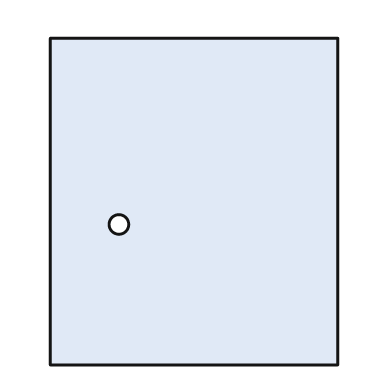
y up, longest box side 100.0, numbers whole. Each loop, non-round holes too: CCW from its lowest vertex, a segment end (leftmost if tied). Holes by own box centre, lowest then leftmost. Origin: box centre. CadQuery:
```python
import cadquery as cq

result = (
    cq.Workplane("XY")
    .moveTo(-44.0, -50.0)
    .lineTo(44.0, -50.0)
    .lineTo(44.0, 50.0)
    .lineTo(-44.0, 50.0)
    .close()
    .moveTo(-23.0, -7.0)
    .circle(3.0)
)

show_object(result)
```